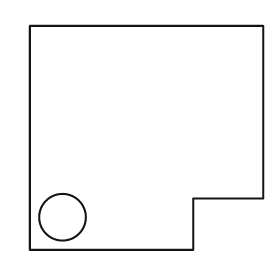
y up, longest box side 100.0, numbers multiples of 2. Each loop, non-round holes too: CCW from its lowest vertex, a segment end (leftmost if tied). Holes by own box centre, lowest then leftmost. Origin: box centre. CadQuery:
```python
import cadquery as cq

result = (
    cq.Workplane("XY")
    .moveTo(-50.0, -48.0)
    .lineTo(20.0, -48.0)
    .lineTo(20.0, -26.0)
    .lineTo(50.0, -26.0)
    .lineTo(50.0, 48.0)
    .lineTo(-50.0, 48.0)
    .close()
    .moveTo(-36.0, -34.0)
    .circle(10.0)
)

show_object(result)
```